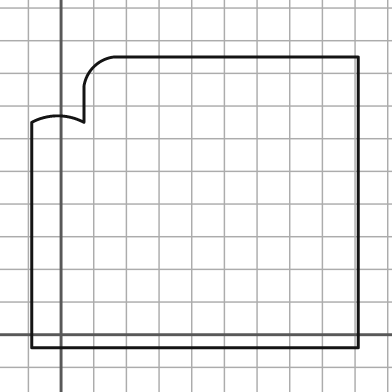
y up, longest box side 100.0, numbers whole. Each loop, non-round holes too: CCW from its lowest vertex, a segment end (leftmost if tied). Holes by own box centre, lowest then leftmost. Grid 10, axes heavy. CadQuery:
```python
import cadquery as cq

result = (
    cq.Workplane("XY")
    .moveTo(-9.0, -4.0)
    .lineTo(91.0, -4.0)
    .lineTo(91.0, 85.0)
    .lineTo(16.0, 85.0)
    .threePointArc((10.0, 82.0), (7.0, 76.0))
    .lineTo(7.0, 65.0)
    .threePointArc((-1.0, 67.0), (-9.0, 65.0))
    .close()
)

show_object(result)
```